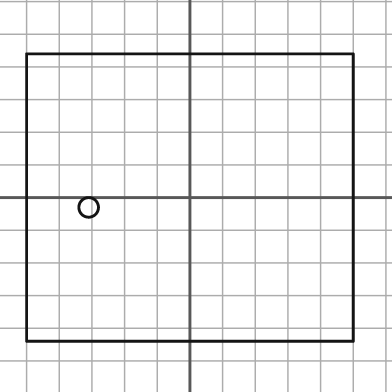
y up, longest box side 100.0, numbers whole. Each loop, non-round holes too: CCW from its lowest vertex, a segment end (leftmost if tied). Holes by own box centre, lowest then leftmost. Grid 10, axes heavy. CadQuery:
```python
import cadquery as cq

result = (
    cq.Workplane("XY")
    .moveTo(-50.0, -44.0)
    .lineTo(50.0, -44.0)
    .lineTo(50.0, 44.0)
    .lineTo(-50.0, 44.0)
    .close()
    .moveTo(-31.0, -3.0)
    .circle(3.0)
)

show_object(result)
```